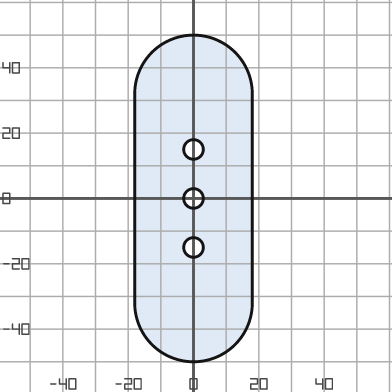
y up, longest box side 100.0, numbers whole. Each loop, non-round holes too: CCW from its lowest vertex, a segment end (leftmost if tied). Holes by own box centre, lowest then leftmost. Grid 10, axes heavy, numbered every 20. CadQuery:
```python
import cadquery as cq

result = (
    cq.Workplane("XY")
    .moveTo(-18.0, -32.0)
    .threePointArc((0.0, -50.0), (18.0, -32.0))
    .lineTo(18.0, 32.0)
    .threePointArc((0.0, 50.0), (-18.0, 32.0))
    .close()
    .moveTo(0.0, -15.0)
    .circle(3.0)
    .moveTo(0.0, 0.0)
    .circle(3.0)
    .moveTo(0.0, 15.0)
    .circle(3.0)
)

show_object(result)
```